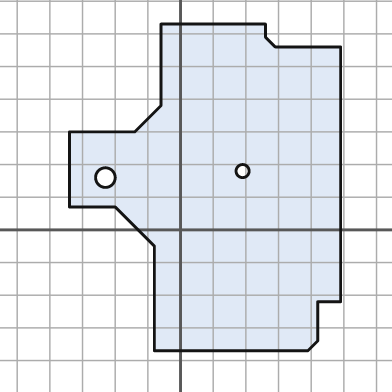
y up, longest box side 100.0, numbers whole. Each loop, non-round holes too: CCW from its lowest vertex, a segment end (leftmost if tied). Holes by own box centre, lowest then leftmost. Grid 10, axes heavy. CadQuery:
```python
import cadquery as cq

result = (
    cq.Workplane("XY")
    .moveTo(-8.0, -37.0)
    .lineTo(39.0, -37.0)
    .lineTo(42.0, -34.0)
    .lineTo(42.0, -22.0)
    .lineTo(49.0, -22.0)
    .lineTo(49.0, 56.0)
    .lineTo(29.0, 56.0)
    .lineTo(26.0, 59.0)
    .lineTo(26.0, 63.0)
    .lineTo(-6.0, 63.0)
    .lineTo(-6.0, 38.0)
    .lineTo(-14.0, 30.0)
    .lineTo(-34.0, 30.0)
    .lineTo(-34.0, 7.0)
    .lineTo(-20.0, 7.0)
    .lineTo(-8.0, -5.0)
    .close()
    .moveTo(-23.0, 16.0)
    .circle(3.0)
    .moveTo(19.0, 18.0)
    .circle(2.0)
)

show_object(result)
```